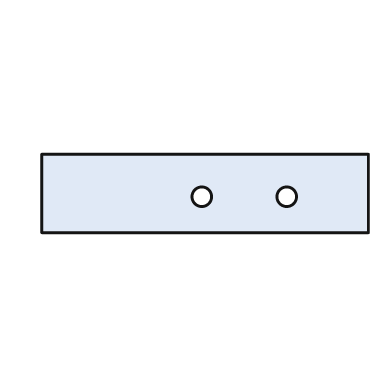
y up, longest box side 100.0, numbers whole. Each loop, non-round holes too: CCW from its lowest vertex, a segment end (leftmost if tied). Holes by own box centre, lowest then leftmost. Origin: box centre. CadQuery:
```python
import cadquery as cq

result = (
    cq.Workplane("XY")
    .moveTo(-50.0, -12.0)
    .lineTo(50.0, -12.0)
    .lineTo(50.0, 12.0)
    .lineTo(-50.0, 12.0)
    .close()
    .moveTo(-1.0, -1.0)
    .circle(3.0)
    .moveTo(25.0, -1.0)
    .circle(3.0)
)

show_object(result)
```